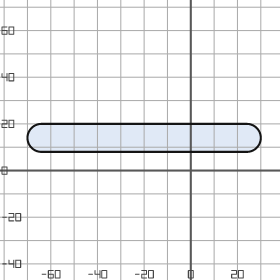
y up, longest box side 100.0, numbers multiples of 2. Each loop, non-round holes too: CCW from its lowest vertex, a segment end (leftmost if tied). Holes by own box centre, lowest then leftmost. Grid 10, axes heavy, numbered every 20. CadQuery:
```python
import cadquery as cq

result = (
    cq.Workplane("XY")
    .moveTo(-64.0, 8.0)
    .lineTo(24.0, 8.0)
    .threePointArc((30.0, 14.0), (24.0, 20.0))
    .lineTo(-64.0, 20.0)
    .threePointArc((-70.0, 14.0), (-64.0, 8.0))
    .close()
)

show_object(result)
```